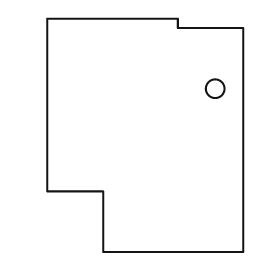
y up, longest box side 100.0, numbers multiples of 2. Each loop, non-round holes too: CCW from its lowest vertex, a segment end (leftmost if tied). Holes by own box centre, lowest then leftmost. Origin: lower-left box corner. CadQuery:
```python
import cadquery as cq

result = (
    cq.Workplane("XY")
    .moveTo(24.0, 0.0)
    .lineTo(84.0, 0.0)
    .lineTo(84.0, 96.0)
    .lineTo(56.0, 96.0)
    .lineTo(56.0, 100.0)
    .lineTo(0.0, 100.0)
    .lineTo(0.0, 26.0)
    .lineTo(24.0, 26.0)
    .close()
    .moveTo(72.0, 70.0)
    .circle(4.0)
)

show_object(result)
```